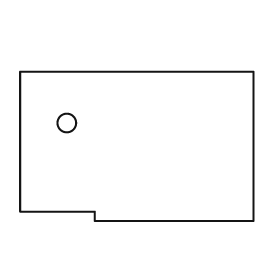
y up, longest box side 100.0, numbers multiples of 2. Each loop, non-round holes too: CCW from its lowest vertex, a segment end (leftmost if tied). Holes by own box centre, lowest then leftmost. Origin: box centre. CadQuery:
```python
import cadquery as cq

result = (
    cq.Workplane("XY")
    .moveTo(-18.0, -32.0)
    .lineTo(50.0, -32.0)
    .lineTo(50.0, 32.0)
    .lineTo(-50.0, 32.0)
    .lineTo(-50.0, -28.0)
    .lineTo(-18.0, -28.0)
    .close()
    .moveTo(-30.0, 10.0)
    .circle(4.0)
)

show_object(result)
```